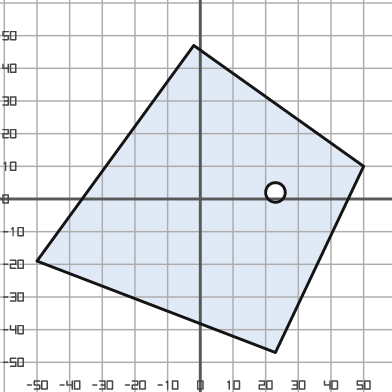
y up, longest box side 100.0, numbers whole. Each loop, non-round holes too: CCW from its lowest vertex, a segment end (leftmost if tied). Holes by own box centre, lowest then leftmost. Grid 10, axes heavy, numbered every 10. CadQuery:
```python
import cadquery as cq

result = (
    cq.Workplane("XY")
    .moveTo(23.0, -47.0)
    .lineTo(50.0, 10.0)
    .lineTo(-2.0, 47.0)
    .lineTo(-50.0, -19.0)
    .close()
    .moveTo(23.0, 2.0)
    .circle(3.0)
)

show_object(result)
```